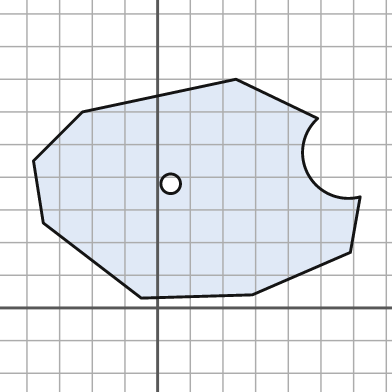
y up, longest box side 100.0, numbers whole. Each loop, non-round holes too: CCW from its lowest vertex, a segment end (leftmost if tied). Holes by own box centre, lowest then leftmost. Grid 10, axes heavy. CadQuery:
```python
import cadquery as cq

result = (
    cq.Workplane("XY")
    .moveTo(-5.0, 3.0)
    .lineTo(29.0, 4.0)
    .lineTo(59.0, 17.0)
    .lineTo(62.0, 34.0)
    .threePointArc((46.0, 41.0), (49.0, 58.0))
    .lineTo(24.0, 70.0)
    .lineTo(-23.0, 60.0)
    .lineTo(-38.0, 45.0)
    .lineTo(-35.0, 26.0)
    .close()
    .moveTo(4.0, 38.0)
    .circle(3.0)
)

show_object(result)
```